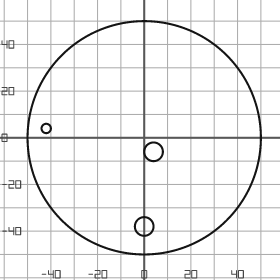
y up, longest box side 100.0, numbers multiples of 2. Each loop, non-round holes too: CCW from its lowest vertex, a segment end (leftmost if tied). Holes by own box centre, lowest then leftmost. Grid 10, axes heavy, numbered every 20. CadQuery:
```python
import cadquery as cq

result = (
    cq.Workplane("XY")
    .moveTo(0.0, 0.0)
    .circle(50.0)
    .moveTo(0.0, -38.0)
    .circle(4.0)
    .moveTo(4.0, -6.0)
    .circle(4.0)
    .moveTo(-42.0, 4.0)
    .circle(2.0)
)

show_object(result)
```